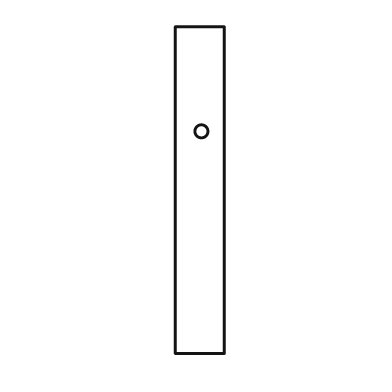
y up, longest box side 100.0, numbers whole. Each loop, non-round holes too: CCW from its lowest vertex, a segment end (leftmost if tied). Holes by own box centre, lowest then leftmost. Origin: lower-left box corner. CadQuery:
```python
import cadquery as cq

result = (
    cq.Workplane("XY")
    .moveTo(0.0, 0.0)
    .lineTo(15.0, 0.0)
    .lineTo(15.0, 100.0)
    .lineTo(0.0, 100.0)
    .close()
    .moveTo(8.0, 68.0)
    .circle(2.0)
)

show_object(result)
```